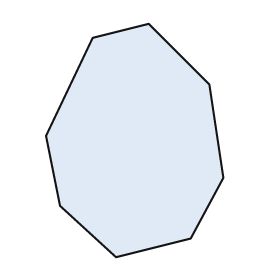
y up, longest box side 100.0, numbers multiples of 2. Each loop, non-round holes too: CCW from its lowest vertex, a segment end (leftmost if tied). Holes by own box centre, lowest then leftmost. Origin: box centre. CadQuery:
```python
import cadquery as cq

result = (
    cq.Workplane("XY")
    .moveTo(-8.0, -50.0)
    .lineTo(24.0, -42.0)
    .lineTo(38.0, -16.0)
    .lineTo(32.0, 24.0)
    .lineTo(6.0, 50.0)
    .lineTo(-18.0, 44.0)
    .lineTo(-38.0, 2.0)
    .lineTo(-32.0, -28.0)
    .close()
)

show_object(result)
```